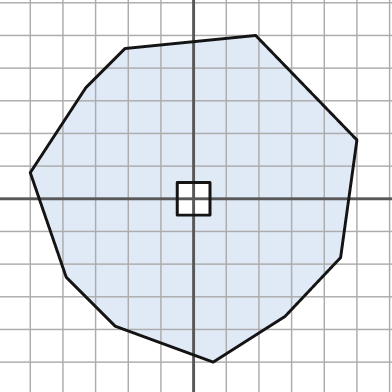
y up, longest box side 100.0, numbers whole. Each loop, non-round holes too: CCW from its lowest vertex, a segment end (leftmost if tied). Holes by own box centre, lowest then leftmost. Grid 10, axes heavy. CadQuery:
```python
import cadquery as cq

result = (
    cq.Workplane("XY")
    .moveTo(6.0, -50.0)
    .lineTo(28.0, -36.0)
    .lineTo(45.0, -18.0)
    .lineTo(50.0, 18.0)
    .lineTo(19.0, 50.0)
    .lineTo(-21.0, 46.0)
    .lineTo(-33.0, 34.0)
    .lineTo(-50.0, 8.0)
    .lineTo(-39.0, -24.0)
    .lineTo(-24.0, -39.0)
    .close()
    .moveTo(-5.0, -5.0)
    .lineTo(5.0, -5.0)
    .lineTo(5.0, 5.0)
    .lineTo(-5.0, 5.0)
    .close()
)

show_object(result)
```